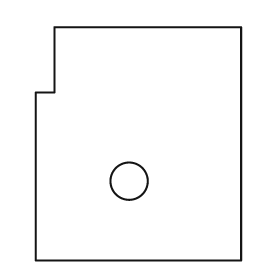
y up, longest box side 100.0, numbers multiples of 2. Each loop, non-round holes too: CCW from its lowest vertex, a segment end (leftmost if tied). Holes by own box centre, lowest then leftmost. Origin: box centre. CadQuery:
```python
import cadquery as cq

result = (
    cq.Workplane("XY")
    .moveTo(-44.0, -50.0)
    .lineTo(44.0, -50.0)
    .lineTo(44.0, 50.0)
    .lineTo(-36.0, 50.0)
    .lineTo(-36.0, 22.0)
    .lineTo(-44.0, 22.0)
    .close()
    .moveTo(-4.0, -16.0)
    .circle(8.0)
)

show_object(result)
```